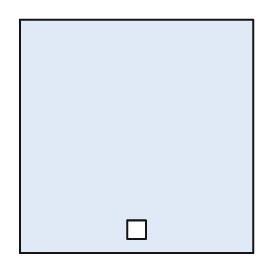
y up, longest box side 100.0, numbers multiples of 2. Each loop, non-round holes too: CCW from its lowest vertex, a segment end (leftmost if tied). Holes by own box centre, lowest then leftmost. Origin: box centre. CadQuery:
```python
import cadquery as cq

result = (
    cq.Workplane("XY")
    .moveTo(-50.0, -50.0)
    .lineTo(50.0, -50.0)
    .lineTo(50.0, 50.0)
    .lineTo(-50.0, 50.0)
    .close()
    .moveTo(-4.0, -44.0)
    .lineTo(4.0, -44.0)
    .lineTo(4.0, -36.0)
    .lineTo(-4.0, -36.0)
    .close()
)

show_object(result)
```